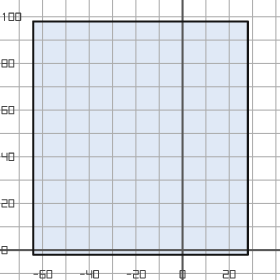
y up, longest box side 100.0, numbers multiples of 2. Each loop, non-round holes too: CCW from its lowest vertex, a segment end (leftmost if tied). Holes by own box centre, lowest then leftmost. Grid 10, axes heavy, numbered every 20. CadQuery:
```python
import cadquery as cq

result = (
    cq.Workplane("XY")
    .moveTo(-64.0, -2.0)
    .lineTo(28.0, -2.0)
    .lineTo(28.0, 98.0)
    .lineTo(-64.0, 98.0)
    .close()
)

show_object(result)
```